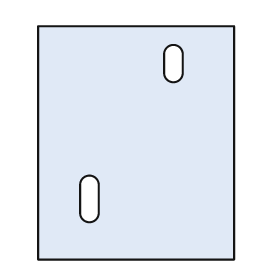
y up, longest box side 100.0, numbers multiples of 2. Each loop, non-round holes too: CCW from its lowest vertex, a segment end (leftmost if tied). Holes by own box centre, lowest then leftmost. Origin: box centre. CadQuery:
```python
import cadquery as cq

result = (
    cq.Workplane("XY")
    .moveTo(-42.0, -50.0)
    .lineTo(42.0, -50.0)
    .lineTo(42.0, 50.0)
    .lineTo(-42.0, 50.0)
    .close()
    .moveTo(-24.0, -30.0)
    .threePointArc((-20.0, -34.0), (-16.0, -30.0))
    .lineTo(-16.0, -18.0)
    .threePointArc((-20.0, -14.0), (-24.0, -18.0))
    .close()
    .moveTo(12.0, 30.0)
    .threePointArc((16.0, 26.0), (20.0, 30.0))
    .lineTo(20.0, 38.0)
    .threePointArc((16.0, 42.0), (12.0, 38.0))
    .close()
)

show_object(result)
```